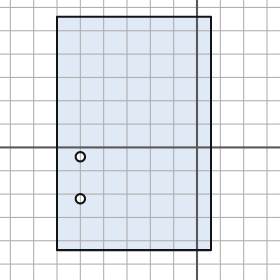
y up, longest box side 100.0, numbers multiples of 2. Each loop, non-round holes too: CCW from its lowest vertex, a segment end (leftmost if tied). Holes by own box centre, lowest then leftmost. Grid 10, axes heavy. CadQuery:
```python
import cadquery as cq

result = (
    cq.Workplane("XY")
    .moveTo(-60.0, -44.0)
    .lineTo(6.0, -44.0)
    .lineTo(6.0, 56.0)
    .lineTo(-60.0, 56.0)
    .close()
    .moveTo(-50.0, -22.0)
    .circle(2.0)
    .moveTo(-50.0, -4.0)
    .circle(2.0)
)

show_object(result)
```